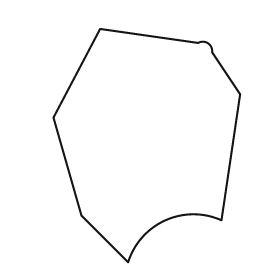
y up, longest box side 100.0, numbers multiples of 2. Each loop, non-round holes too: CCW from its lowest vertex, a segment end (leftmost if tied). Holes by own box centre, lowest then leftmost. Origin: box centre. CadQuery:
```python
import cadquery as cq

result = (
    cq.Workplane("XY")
    .moveTo(-8.0, -50.0)
    .threePointArc((8.0, -32.0), (32.0, -32.0))
    .lineTo(40.0, 22.0)
    .lineTo(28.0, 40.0)
    .threePointArc((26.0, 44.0), (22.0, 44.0))
    .lineTo(-20.0, 50.0)
    .lineTo(-40.0, 12.0)
    .lineTo(-28.0, -30.0)
    .close()
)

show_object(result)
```